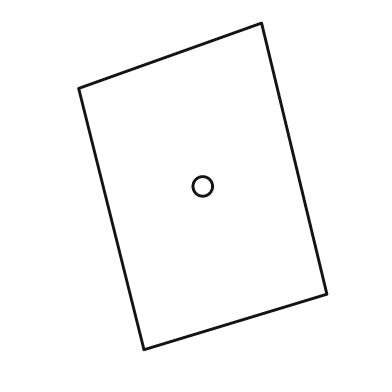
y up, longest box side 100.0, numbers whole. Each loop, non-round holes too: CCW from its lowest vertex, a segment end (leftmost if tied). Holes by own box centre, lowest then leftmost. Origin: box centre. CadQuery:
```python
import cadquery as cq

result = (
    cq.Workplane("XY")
    .moveTo(-18.0, -50.0)
    .lineTo(38.0, -33.0)
    .lineTo(18.0, 50.0)
    .lineTo(-38.0, 30.0)
    .close()
    .moveTo(0.0, 0.0)
    .circle(3.0)
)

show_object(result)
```